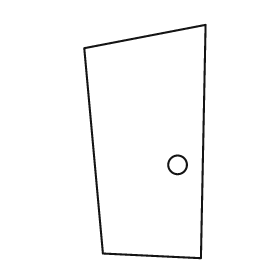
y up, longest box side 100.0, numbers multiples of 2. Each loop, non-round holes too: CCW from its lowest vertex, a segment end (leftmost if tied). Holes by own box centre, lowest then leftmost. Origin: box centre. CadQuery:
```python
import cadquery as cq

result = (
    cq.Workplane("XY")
    .moveTo(24.0, -50.0)
    .lineTo(26.0, 50.0)
    .lineTo(-26.0, 40.0)
    .lineTo(-18.0, -48.0)
    .close()
    .moveTo(14.0, -10.0)
    .circle(4.0)
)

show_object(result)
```